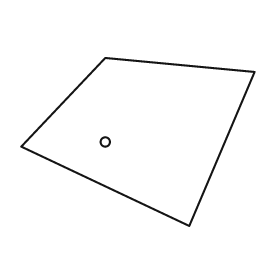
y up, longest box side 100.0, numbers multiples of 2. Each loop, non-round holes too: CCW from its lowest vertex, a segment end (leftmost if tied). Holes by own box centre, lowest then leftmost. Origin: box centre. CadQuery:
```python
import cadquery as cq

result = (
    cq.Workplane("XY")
    .moveTo(22.0, -36.0)
    .lineTo(50.0, 30.0)
    .lineTo(-14.0, 36.0)
    .lineTo(-50.0, -2.0)
    .close()
    .moveTo(-14.0, 0.0)
    .circle(2.0)
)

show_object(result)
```